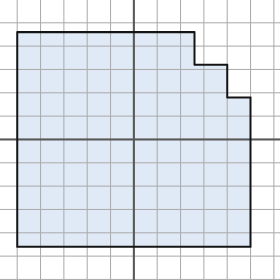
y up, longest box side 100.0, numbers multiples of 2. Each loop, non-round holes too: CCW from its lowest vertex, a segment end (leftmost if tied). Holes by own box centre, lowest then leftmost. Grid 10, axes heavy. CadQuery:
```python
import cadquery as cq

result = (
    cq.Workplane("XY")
    .moveTo(-50.0, -46.0)
    .lineTo(50.0, -46.0)
    .lineTo(50.0, 18.0)
    .lineTo(40.0, 18.0)
    .lineTo(40.0, 32.0)
    .lineTo(26.0, 32.0)
    .lineTo(26.0, 46.0)
    .lineTo(-50.0, 46.0)
    .close()
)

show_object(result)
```